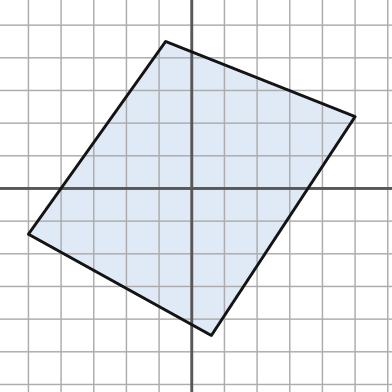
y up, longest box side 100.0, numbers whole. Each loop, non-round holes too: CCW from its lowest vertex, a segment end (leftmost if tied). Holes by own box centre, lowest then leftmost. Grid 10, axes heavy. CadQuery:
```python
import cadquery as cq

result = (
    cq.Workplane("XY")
    .moveTo(6.0, -45.0)
    .lineTo(50.0, 22.0)
    .lineTo(-8.0, 45.0)
    .lineTo(-50.0, -14.0)
    .close()
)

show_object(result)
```